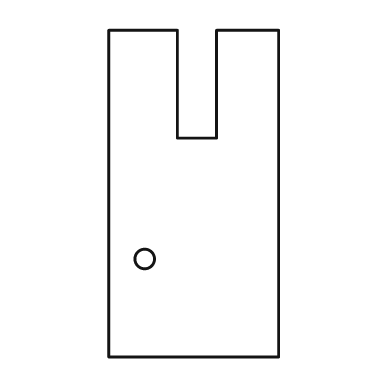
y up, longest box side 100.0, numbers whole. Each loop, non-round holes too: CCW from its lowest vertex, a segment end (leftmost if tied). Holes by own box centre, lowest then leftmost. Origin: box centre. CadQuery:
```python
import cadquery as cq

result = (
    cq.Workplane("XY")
    .moveTo(-26.0, -50.0)
    .lineTo(26.0, -50.0)
    .lineTo(26.0, 50.0)
    .lineTo(7.0, 50.0)
    .lineTo(7.0, 17.0)
    .lineTo(-5.0, 17.0)
    .lineTo(-5.0, 50.0)
    .lineTo(-26.0, 50.0)
    .close()
    .moveTo(-15.0, -20.0)
    .circle(3.0)
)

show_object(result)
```